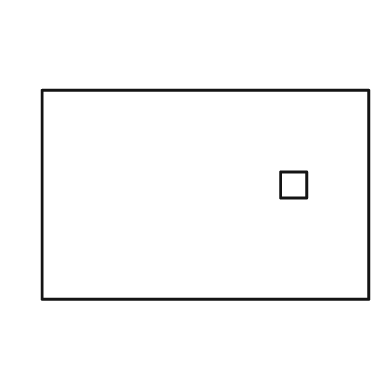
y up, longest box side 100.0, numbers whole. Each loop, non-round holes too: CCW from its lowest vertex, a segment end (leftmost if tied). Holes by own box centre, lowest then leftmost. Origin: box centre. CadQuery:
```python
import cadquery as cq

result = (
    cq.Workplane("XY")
    .moveTo(-50.0, -32.0)
    .lineTo(50.0, -32.0)
    .lineTo(50.0, 32.0)
    .lineTo(-50.0, 32.0)
    .close()
    .moveTo(23.0, -1.0)
    .lineTo(31.0, -1.0)
    .lineTo(31.0, 7.0)
    .lineTo(23.0, 7.0)
    .close()
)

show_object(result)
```